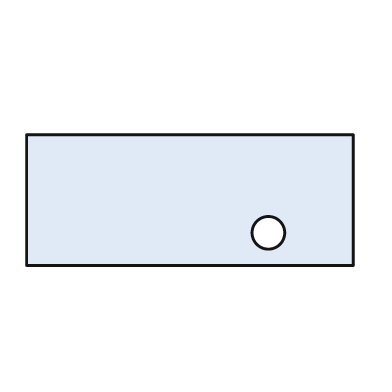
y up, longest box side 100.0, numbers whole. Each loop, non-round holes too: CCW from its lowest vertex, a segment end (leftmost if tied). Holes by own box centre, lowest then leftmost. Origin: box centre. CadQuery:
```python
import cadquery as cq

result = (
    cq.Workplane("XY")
    .moveTo(-50.0, -20.0)
    .lineTo(50.0, -20.0)
    .lineTo(50.0, 20.0)
    .lineTo(-50.0, 20.0)
    .close()
    .moveTo(24.0, -10.0)
    .circle(5.0)
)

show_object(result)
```